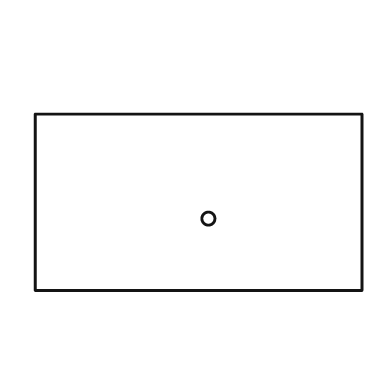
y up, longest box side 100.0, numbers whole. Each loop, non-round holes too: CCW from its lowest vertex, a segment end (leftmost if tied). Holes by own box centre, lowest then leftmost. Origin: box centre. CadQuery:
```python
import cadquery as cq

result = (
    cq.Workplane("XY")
    .moveTo(-50.0, -27.0)
    .lineTo(50.0, -27.0)
    .lineTo(50.0, 27.0)
    .lineTo(-50.0, 27.0)
    .close()
    .moveTo(3.0, -5.0)
    .circle(2.0)
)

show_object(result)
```